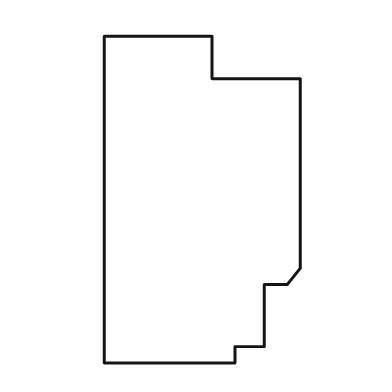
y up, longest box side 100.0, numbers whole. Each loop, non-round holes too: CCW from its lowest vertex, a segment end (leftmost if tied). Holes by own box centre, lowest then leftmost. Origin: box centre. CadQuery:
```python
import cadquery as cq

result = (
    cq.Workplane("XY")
    .moveTo(-30.0, -50.0)
    .lineTo(10.0, -50.0)
    .lineTo(10.0, -45.0)
    .lineTo(19.0, -45.0)
    .lineTo(19.0, -26.0)
    .lineTo(26.0, -26.0)
    .lineTo(30.0, -21.0)
    .lineTo(30.0, 37.0)
    .lineTo(3.0, 37.0)
    .lineTo(3.0, 50.0)
    .lineTo(-30.0, 50.0)
    .close()
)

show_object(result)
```